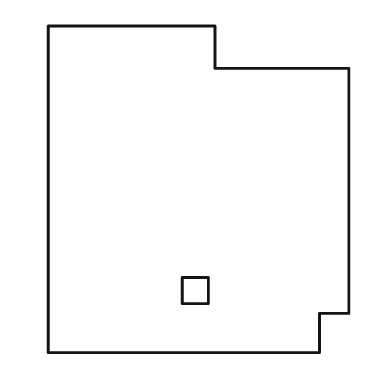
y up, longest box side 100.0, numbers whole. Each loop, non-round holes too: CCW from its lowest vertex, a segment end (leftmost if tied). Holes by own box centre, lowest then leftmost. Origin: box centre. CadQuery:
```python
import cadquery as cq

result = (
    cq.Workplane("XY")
    .moveTo(-46.0, -50.0)
    .lineTo(37.0, -50.0)
    .lineTo(37.0, -38.0)
    .lineTo(46.0, -38.0)
    .lineTo(46.0, 37.0)
    .lineTo(5.0, 37.0)
    .lineTo(5.0, 50.0)
    .lineTo(-46.0, 50.0)
    .close()
    .moveTo(-5.0, -35.0)
    .lineTo(3.0, -35.0)
    .lineTo(3.0, -27.0)
    .lineTo(-5.0, -27.0)
    .close()
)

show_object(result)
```